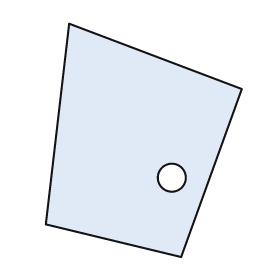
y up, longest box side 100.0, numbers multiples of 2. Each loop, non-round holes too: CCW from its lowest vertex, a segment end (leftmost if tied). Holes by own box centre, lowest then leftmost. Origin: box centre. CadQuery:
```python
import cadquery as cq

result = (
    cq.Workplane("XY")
    .moveTo(16.0, -50.0)
    .lineTo(42.0, 22.0)
    .lineTo(-32.0, 50.0)
    .lineTo(-42.0, -36.0)
    .close()
    .moveTo(12.0, -16.0)
    .circle(6.0)
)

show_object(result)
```